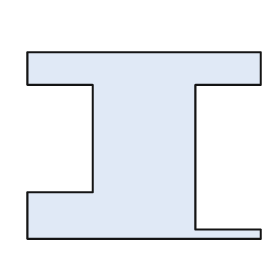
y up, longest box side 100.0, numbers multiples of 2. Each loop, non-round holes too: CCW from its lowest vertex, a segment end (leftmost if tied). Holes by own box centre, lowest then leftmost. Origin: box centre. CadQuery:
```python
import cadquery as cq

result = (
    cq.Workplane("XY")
    .moveTo(-50.0, -40.0)
    .lineTo(50.0, -40.0)
    .lineTo(50.0, -36.0)
    .lineTo(22.0, -36.0)
    .lineTo(22.0, 26.0)
    .lineTo(50.0, 26.0)
    .lineTo(50.0, 40.0)
    .lineTo(-50.0, 40.0)
    .lineTo(-50.0, 26.0)
    .lineTo(-22.0, 26.0)
    .lineTo(-22.0, -20.0)
    .lineTo(-50.0, -20.0)
    .close()
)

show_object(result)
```